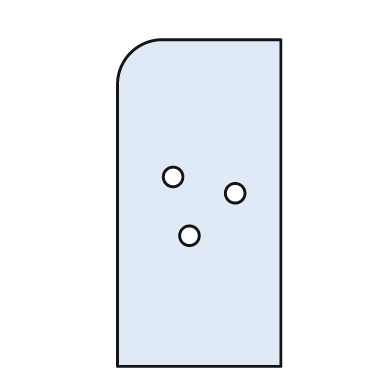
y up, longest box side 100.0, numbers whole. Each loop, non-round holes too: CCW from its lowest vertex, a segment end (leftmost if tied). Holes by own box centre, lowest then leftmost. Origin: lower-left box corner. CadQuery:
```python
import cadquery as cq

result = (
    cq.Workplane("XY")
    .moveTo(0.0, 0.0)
    .lineTo(50.0, 0.0)
    .lineTo(50.0, 100.0)
    .lineTo(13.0, 100.0)
    .threePointArc((4.0, 96.0), (0.0, 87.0))
    .close()
    .moveTo(22.0, 40.0)
    .circle(3.0)
    .moveTo(36.0, 53.0)
    .circle(3.0)
    .moveTo(17.0, 58.0)
    .circle(3.0)
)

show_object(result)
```